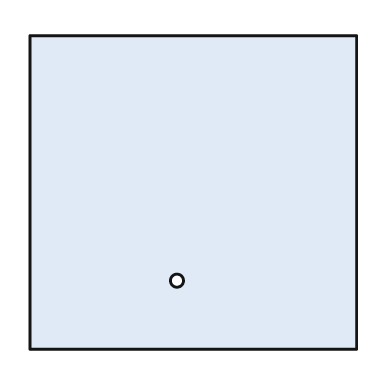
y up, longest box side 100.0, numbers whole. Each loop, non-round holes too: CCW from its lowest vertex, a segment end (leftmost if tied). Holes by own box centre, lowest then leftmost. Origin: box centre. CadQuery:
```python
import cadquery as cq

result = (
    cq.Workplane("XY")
    .moveTo(-50.0, -48.0)
    .lineTo(50.0, -48.0)
    .lineTo(50.0, 48.0)
    .lineTo(-50.0, 48.0)
    .close()
    .moveTo(-5.0, -27.0)
    .circle(2.0)
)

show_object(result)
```